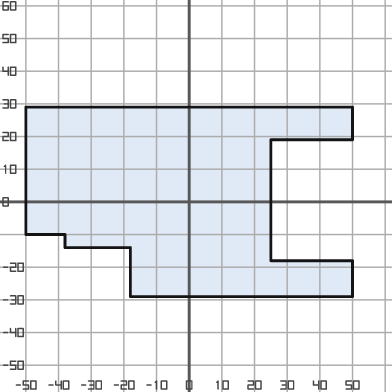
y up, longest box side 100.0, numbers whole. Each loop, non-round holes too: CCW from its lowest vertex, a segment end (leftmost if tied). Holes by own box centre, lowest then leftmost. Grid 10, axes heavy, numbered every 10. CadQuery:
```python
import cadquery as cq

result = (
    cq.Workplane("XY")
    .moveTo(-18.0, -29.0)
    .lineTo(50.0, -29.0)
    .lineTo(50.0, -18.0)
    .lineTo(25.0, -18.0)
    .lineTo(25.0, 19.0)
    .lineTo(50.0, 19.0)
    .lineTo(50.0, 29.0)
    .lineTo(-50.0, 29.0)
    .lineTo(-50.0, -10.0)
    .lineTo(-38.0, -10.0)
    .lineTo(-38.0, -14.0)
    .lineTo(-18.0, -14.0)
    .close()
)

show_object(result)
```